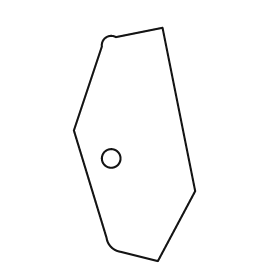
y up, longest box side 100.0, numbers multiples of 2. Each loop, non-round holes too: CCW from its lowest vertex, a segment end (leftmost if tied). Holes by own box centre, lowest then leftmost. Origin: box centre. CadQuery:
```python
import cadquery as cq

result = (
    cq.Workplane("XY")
    .moveTo(10.0, -50.0)
    .lineTo(26.0, -20.0)
    .lineTo(12.0, 50.0)
    .lineTo(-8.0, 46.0)
    .threePointArc((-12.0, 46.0), (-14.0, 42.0))
    .lineTo(-26.0, 6.0)
    .lineTo(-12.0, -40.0)
    .threePointArc((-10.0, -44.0), (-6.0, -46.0))
    .close()
    .moveTo(-10.0, -6.0)
    .circle(4.0)
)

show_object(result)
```